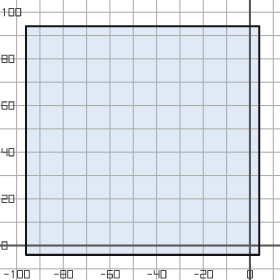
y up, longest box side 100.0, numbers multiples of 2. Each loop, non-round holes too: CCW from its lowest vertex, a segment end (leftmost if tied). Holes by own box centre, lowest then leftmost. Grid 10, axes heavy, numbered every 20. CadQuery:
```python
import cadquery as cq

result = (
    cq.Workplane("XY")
    .moveTo(-96.0, -4.0)
    .lineTo(4.0, -4.0)
    .lineTo(4.0, 94.0)
    .lineTo(-96.0, 94.0)
    .close()
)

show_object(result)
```